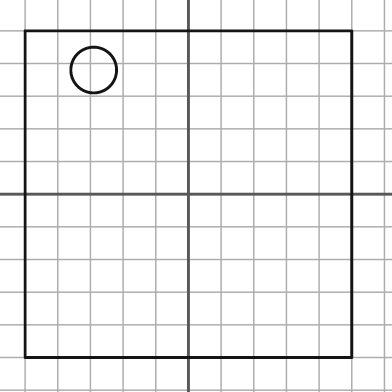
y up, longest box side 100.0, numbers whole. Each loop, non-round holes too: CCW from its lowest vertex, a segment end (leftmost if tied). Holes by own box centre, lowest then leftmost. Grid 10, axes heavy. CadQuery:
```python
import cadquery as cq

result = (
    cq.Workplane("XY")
    .moveTo(-50.0, -50.0)
    .lineTo(50.0, -50.0)
    .lineTo(50.0, 50.0)
    .lineTo(-50.0, 50.0)
    .close()
    .moveTo(-29.0, 38.0)
    .circle(7.0)
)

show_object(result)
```